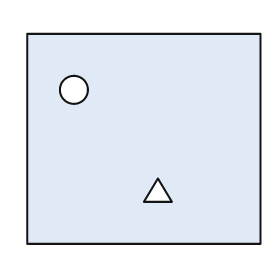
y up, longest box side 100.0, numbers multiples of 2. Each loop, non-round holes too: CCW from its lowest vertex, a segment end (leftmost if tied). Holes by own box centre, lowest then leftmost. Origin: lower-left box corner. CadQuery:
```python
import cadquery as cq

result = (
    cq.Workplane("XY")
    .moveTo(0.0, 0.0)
    .lineTo(100.0, 0.0)
    .lineTo(100.0, 90.0)
    .lineTo(0.0, 90.0)
    .close()
    .moveTo(50.0, 18.0)
    .lineTo(62.0, 18.0)
    .lineTo(56.0, 28.0)
    .close()
    .moveTo(20.0, 66.0)
    .circle(6.0)
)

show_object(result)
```